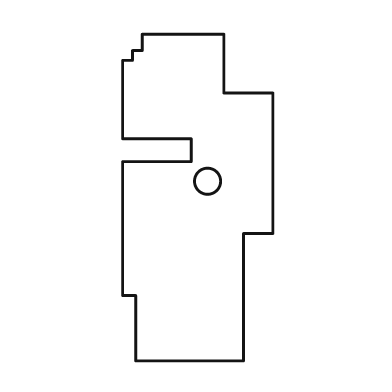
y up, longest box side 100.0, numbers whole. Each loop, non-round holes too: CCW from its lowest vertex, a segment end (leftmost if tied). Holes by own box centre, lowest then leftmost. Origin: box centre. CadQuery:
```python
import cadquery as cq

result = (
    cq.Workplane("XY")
    .moveTo(-19.0, -50.0)
    .lineTo(14.0, -50.0)
    .lineTo(14.0, -11.0)
    .lineTo(23.0, -11.0)
    .lineTo(23.0, 32.0)
    .lineTo(8.0, 32.0)
    .lineTo(8.0, 50.0)
    .lineTo(-17.0, 50.0)
    .lineTo(-17.0, 45.0)
    .lineTo(-20.0, 45.0)
    .lineTo(-20.0, 42.0)
    .lineTo(-23.0, 42.0)
    .lineTo(-23.0, 18.0)
    .lineTo(-2.0, 18.0)
    .lineTo(-2.0, 11.0)
    .lineTo(-23.0, 11.0)
    .lineTo(-23.0, -30.0)
    .lineTo(-19.0, -30.0)
    .close()
    .moveTo(3.0, 5.0)
    .circle(4.0)
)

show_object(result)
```